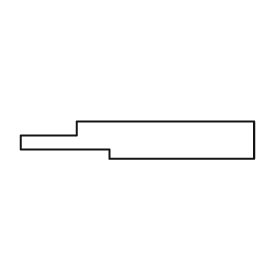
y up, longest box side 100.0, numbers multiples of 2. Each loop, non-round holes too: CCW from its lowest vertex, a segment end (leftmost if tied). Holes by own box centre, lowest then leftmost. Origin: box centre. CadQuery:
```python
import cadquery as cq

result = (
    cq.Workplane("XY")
    .moveTo(-12.0, -8.0)
    .lineTo(50.0, -8.0)
    .lineTo(50.0, 8.0)
    .lineTo(-26.0, 8.0)
    .lineTo(-26.0, 2.0)
    .lineTo(-50.0, 2.0)
    .lineTo(-50.0, -4.0)
    .lineTo(-12.0, -4.0)
    .close()
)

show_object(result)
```